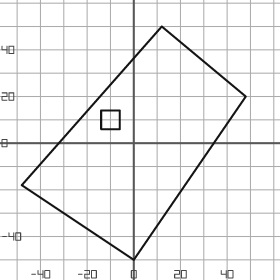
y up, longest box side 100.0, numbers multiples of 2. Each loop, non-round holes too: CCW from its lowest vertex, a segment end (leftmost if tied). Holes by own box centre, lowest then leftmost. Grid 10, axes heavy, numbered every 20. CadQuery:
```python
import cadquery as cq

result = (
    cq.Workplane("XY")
    .moveTo(0.0, -50.0)
    .lineTo(48.0, 20.0)
    .lineTo(12.0, 50.0)
    .lineTo(-48.0, -18.0)
    .close()
    .moveTo(-14.0, 6.0)
    .lineTo(-6.0, 6.0)
    .lineTo(-6.0, 14.0)
    .lineTo(-14.0, 14.0)
    .close()
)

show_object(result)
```